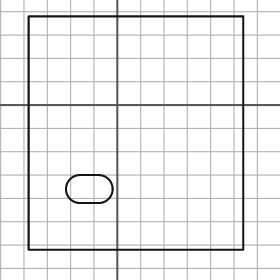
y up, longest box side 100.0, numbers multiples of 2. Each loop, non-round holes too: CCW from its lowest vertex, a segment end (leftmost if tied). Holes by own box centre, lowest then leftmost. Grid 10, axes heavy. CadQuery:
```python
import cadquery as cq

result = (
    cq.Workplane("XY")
    .moveTo(-38.0, -62.0)
    .lineTo(54.0, -62.0)
    .lineTo(54.0, 38.0)
    .lineTo(-38.0, 38.0)
    .close()
    .moveTo(-16.0, -42.0)
    .lineTo(-8.0, -42.0)
    .threePointArc((-2.0, -36.0), (-8.0, -30.0))
    .lineTo(-16.0, -30.0)
    .threePointArc((-22.0, -36.0), (-16.0, -42.0))
    .close()
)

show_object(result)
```